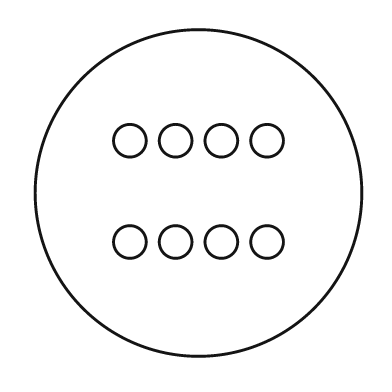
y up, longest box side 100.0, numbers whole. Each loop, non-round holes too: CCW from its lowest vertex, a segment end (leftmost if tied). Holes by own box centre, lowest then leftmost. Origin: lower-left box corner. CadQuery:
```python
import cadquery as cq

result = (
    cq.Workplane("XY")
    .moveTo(50.0, 50.0)
    .circle(50.0)
    .moveTo(29.0, 35.0)
    .circle(5.0)
    .moveTo(43.0, 35.0)
    .circle(5.0)
    .moveTo(57.0, 35.0)
    .circle(5.0)
    .moveTo(71.0, 35.0)
    .circle(5.0)
    .moveTo(29.0, 66.0)
    .circle(5.0)
    .moveTo(43.0, 66.0)
    .circle(5.0)
    .moveTo(57.0, 66.0)
    .circle(5.0)
    .moveTo(71.0, 66.0)
    .circle(5.0)
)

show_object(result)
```